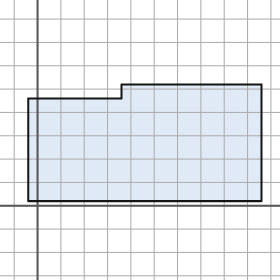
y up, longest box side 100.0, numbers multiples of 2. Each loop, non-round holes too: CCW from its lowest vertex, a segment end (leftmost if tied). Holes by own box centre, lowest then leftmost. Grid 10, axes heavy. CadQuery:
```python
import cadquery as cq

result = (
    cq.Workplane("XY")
    .moveTo(-4.0, 2.0)
    .lineTo(96.0, 2.0)
    .lineTo(96.0, 52.0)
    .lineTo(36.0, 52.0)
    .lineTo(36.0, 46.0)
    .lineTo(-4.0, 46.0)
    .close()
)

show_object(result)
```